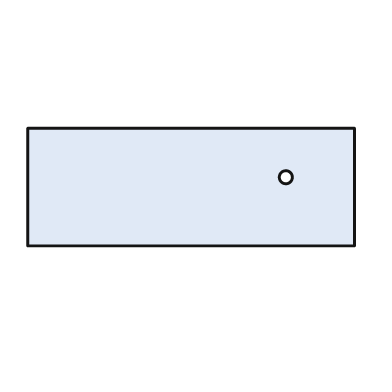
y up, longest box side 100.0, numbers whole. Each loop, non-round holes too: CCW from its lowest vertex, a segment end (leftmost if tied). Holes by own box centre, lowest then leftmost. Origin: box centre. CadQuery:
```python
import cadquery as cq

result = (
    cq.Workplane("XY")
    .moveTo(-50.0, -18.0)
    .lineTo(50.0, -18.0)
    .lineTo(50.0, 18.0)
    .lineTo(-50.0, 18.0)
    .close()
    .moveTo(29.0, 3.0)
    .circle(2.0)
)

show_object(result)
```